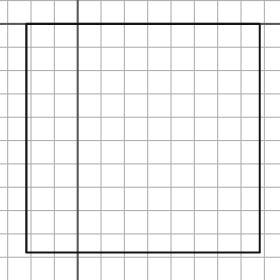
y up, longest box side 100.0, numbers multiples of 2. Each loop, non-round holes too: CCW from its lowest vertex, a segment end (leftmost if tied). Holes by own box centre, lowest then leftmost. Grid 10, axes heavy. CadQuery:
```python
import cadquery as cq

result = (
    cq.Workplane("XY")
    .moveTo(-22.0, -98.0)
    .lineTo(78.0, -98.0)
    .lineTo(78.0, 0.0)
    .lineTo(-22.0, 0.0)
    .close()
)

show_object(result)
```